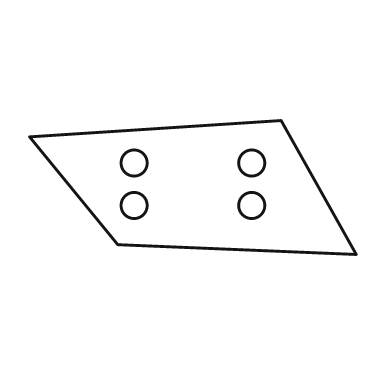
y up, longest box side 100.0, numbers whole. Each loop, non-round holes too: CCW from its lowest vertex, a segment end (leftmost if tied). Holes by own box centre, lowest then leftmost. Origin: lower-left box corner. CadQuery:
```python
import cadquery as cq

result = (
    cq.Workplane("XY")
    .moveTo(100.0, 0.0)
    .lineTo(77.0, 41.0)
    .lineTo(0.0, 36.0)
    .lineTo(27.0, 3.0)
    .close()
    .moveTo(32.0, 15.0)
    .circle(4.0)
    .moveTo(68.0, 15.0)
    .circle(4.0)
    .moveTo(32.0, 28.0)
    .circle(4.0)
    .moveTo(68.0, 28.0)
    .circle(4.0)
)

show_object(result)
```